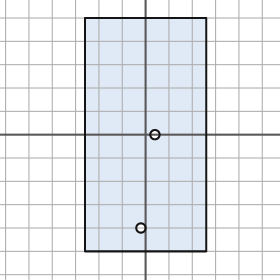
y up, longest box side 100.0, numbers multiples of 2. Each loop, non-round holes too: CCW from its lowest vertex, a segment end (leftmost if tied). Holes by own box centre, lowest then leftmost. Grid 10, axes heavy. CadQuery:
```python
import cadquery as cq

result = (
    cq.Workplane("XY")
    .moveTo(-26.0, -50.0)
    .lineTo(26.0, -50.0)
    .lineTo(26.0, 50.0)
    .lineTo(-26.0, 50.0)
    .close()
    .moveTo(-2.0, -40.0)
    .circle(2.0)
    .moveTo(4.0, 0.0)
    .circle(2.0)
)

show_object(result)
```